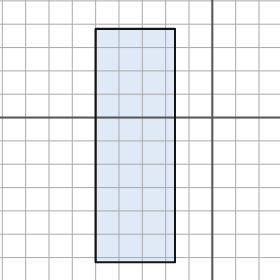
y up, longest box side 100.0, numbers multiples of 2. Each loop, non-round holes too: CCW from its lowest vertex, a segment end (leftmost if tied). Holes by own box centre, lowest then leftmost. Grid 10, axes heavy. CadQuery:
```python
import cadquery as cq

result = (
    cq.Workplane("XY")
    .moveTo(-50.0, -62.0)
    .lineTo(-16.0, -62.0)
    .lineTo(-16.0, 38.0)
    .lineTo(-50.0, 38.0)
    .close()
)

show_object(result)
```